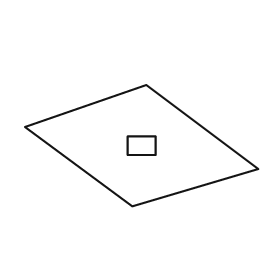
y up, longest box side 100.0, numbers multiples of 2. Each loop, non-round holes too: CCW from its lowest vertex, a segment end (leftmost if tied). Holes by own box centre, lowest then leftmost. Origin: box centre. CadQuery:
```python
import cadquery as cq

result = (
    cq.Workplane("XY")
    .moveTo(-4.0, -26.0)
    .lineTo(50.0, -10.0)
    .lineTo(2.0, 26.0)
    .lineTo(-50.0, 8.0)
    .close()
    .moveTo(-6.0, -4.0)
    .lineTo(6.0, -4.0)
    .lineTo(6.0, 4.0)
    .lineTo(-6.0, 4.0)
    .close()
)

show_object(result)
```